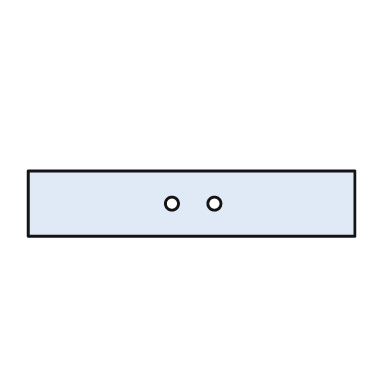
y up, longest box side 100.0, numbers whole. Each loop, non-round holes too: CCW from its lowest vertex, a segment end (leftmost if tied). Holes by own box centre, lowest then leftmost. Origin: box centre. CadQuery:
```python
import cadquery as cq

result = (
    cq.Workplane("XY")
    .moveTo(-50.0, -10.0)
    .lineTo(50.0, -10.0)
    .lineTo(50.0, 10.0)
    .lineTo(-50.0, 10.0)
    .close()
    .moveTo(-6.0, 0.0)
    .circle(2.0)
    .moveTo(7.0, 0.0)
    .circle(2.0)
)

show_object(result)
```